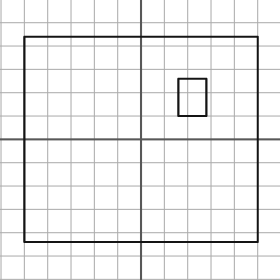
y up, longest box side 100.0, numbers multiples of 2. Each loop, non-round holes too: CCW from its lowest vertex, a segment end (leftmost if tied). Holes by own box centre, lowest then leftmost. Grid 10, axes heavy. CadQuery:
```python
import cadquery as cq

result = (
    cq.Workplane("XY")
    .moveTo(-50.0, -44.0)
    .lineTo(50.0, -44.0)
    .lineTo(50.0, 44.0)
    .lineTo(-50.0, 44.0)
    .close()
    .moveTo(16.0, 10.0)
    .lineTo(28.0, 10.0)
    .lineTo(28.0, 26.0)
    .lineTo(16.0, 26.0)
    .close()
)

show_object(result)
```